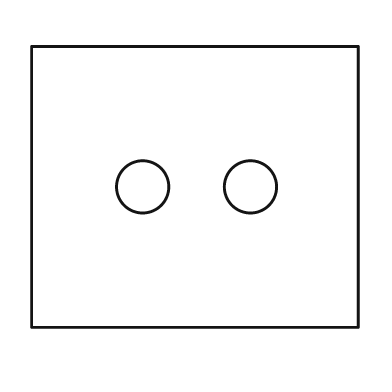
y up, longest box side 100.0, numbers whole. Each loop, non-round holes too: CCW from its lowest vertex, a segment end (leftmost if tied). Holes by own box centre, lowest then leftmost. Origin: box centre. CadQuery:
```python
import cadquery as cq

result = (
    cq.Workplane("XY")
    .moveTo(-50.0, -43.0)
    .lineTo(50.0, -43.0)
    .lineTo(50.0, 43.0)
    .lineTo(-50.0, 43.0)
    .close()
    .moveTo(-16.0, 0.0)
    .circle(8.0)
    .moveTo(17.0, 0.0)
    .circle(8.0)
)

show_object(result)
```